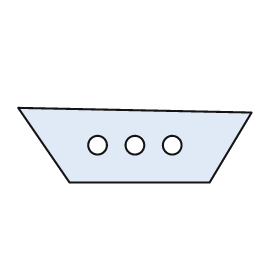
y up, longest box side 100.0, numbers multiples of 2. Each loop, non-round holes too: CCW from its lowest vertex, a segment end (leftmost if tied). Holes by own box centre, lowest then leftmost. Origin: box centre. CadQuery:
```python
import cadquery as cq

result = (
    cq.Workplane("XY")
    .moveTo(-28.0, -16.0)
    .lineTo(32.0, -16.0)
    .lineTo(50.0, 14.0)
    .lineTo(-50.0, 16.0)
    .close()
    .moveTo(-16.0, 0.0)
    .circle(4.0)
    .moveTo(0.0, 0.0)
    .circle(4.0)
    .moveTo(16.0, 0.0)
    .circle(4.0)
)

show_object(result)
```